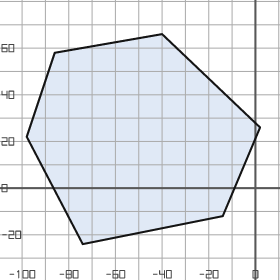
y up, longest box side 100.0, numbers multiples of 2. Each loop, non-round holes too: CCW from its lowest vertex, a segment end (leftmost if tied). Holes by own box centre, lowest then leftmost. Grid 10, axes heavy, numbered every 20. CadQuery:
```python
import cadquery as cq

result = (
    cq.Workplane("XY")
    .moveTo(-74.0, -24.0)
    .lineTo(-14.0, -12.0)
    .lineTo(2.0, 26.0)
    .lineTo(-40.0, 66.0)
    .lineTo(-86.0, 58.0)
    .lineTo(-98.0, 22.0)
    .close()
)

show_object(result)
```